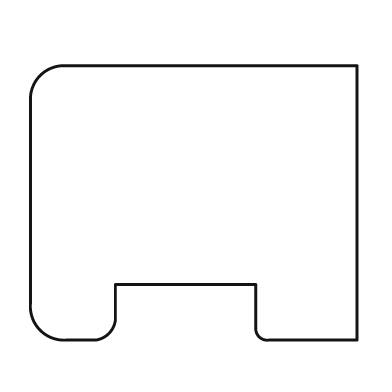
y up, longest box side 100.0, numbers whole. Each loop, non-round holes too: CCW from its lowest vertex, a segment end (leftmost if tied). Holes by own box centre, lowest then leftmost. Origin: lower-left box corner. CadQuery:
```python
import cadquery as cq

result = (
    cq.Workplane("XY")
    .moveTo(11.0, 0.0)
    .lineTo(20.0, 0.0)
    .threePointArc((24.0, 2.0), (26.0, 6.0))
    .lineTo(26.0, 17.0)
    .lineTo(69.0, 17.0)
    .lineTo(69.0, 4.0)
    .threePointArc((70.0, 1.0), (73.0, 0.0))
    .lineTo(100.0, 0.0)
    .lineTo(100.0, 84.0)
    .lineTo(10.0, 84.0)
    .threePointArc((3.0, 81.0), (0.0, 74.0))
    .lineTo(0.0, 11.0)
    .threePointArc((3.0, 3.0), (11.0, 0.0))
    .close()
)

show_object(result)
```